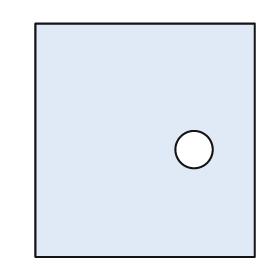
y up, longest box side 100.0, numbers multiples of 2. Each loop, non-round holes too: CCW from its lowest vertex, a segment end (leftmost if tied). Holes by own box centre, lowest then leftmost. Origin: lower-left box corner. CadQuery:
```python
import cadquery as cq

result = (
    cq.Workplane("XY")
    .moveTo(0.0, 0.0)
    .lineTo(94.0, 0.0)
    .lineTo(94.0, 100.0)
    .lineTo(0.0, 100.0)
    .close()
    .moveTo(68.0, 46.0)
    .circle(8.0)
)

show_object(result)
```